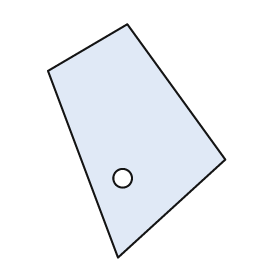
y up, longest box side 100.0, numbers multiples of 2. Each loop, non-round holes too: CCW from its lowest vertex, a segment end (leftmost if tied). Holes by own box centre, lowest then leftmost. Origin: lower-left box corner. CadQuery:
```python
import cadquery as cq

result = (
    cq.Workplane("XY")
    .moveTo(30.0, 0.0)
    .lineTo(76.0, 42.0)
    .lineTo(34.0, 100.0)
    .lineTo(0.0, 80.0)
    .close()
    .moveTo(32.0, 34.0)
    .circle(4.0)
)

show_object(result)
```